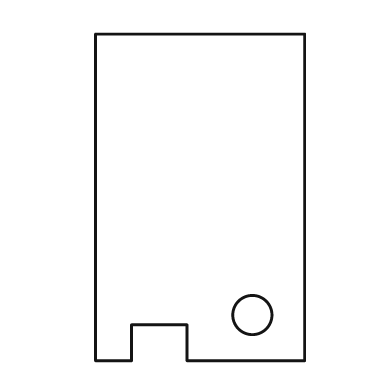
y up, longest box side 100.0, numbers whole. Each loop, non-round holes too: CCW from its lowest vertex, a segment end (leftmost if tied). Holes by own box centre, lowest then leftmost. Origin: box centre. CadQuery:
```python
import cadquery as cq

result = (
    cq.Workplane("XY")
    .moveTo(-32.0, -50.0)
    .lineTo(-21.0, -50.0)
    .lineTo(-21.0, -39.0)
    .lineTo(-4.0, -39.0)
    .lineTo(-4.0, -50.0)
    .lineTo(32.0, -50.0)
    .lineTo(32.0, 50.0)
    .lineTo(-32.0, 50.0)
    .close()
    .moveTo(16.0, -36.0)
    .circle(6.0)
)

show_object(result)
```